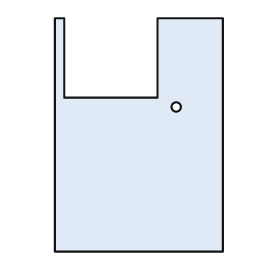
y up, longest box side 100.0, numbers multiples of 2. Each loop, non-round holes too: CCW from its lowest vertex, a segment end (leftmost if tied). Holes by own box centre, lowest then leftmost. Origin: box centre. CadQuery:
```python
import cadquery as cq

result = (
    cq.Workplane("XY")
    .moveTo(-36.0, -50.0)
    .lineTo(36.0, -50.0)
    .lineTo(36.0, 50.0)
    .lineTo(8.0, 50.0)
    .lineTo(8.0, 16.0)
    .lineTo(-32.0, 16.0)
    .lineTo(-32.0, 50.0)
    .lineTo(-36.0, 50.0)
    .close()
    .moveTo(16.0, 12.0)
    .circle(2.0)
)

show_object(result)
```